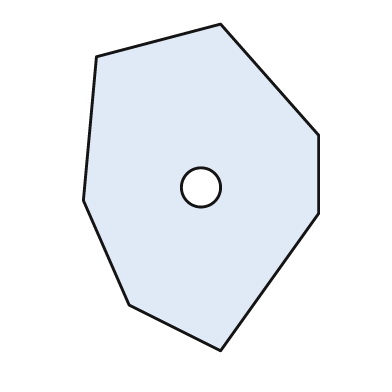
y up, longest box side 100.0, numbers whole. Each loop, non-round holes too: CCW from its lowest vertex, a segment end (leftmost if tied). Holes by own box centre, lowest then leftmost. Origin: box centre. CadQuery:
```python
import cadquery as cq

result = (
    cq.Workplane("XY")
    .moveTo(6.0, -50.0)
    .lineTo(36.0, -8.0)
    .lineTo(36.0, 16.0)
    .lineTo(6.0, 50.0)
    .lineTo(-32.0, 40.0)
    .lineTo(-36.0, -4.0)
    .lineTo(-22.0, -36.0)
    .close()
    .moveTo(0.0, 0.0)
    .circle(6.0)
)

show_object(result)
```